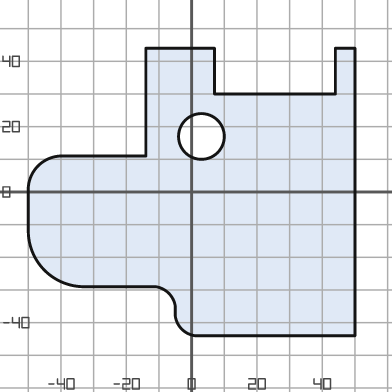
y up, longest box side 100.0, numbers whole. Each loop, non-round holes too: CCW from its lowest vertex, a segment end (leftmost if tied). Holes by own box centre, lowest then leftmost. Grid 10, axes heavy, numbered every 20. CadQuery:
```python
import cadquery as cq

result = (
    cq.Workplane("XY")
    .moveTo(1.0, -44.0)
    .lineTo(50.0, -44.0)
    .lineTo(50.0, 44.0)
    .lineTo(44.0, 44.0)
    .lineTo(44.0, 30.0)
    .lineTo(7.0, 30.0)
    .lineTo(7.0, 44.0)
    .lineTo(-14.0, 44.0)
    .lineTo(-14.0, 11.0)
    .lineTo(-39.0, 11.0)
    .threePointArc((-47.0, 8.0), (-50.0, 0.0))
    .lineTo(-50.0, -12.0)
    .threePointArc((-45.0, -24.0), (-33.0, -29.0))
    .lineTo(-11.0, -29.0)
    .threePointArc((-7.0, -31.0), (-5.0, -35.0))
    .lineTo(-5.0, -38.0)
    .threePointArc((-3.0, -42.0), (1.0, -44.0))
    .close()
    .moveTo(3.0, 17.0)
    .circle(7.0)
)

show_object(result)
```